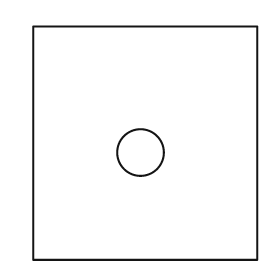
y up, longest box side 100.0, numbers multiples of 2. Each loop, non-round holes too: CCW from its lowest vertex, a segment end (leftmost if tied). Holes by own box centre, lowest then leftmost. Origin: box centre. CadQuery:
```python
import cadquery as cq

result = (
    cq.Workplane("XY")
    .moveTo(-48.0, -50.0)
    .lineTo(48.0, -50.0)
    .lineTo(48.0, 50.0)
    .lineTo(-48.0, 50.0)
    .close()
    .moveTo(-2.0, -4.0)
    .circle(10.0)
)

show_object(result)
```